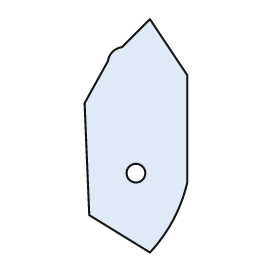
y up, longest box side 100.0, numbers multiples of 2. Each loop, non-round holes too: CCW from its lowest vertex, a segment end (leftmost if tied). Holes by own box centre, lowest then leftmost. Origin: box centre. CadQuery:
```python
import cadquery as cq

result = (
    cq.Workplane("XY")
    .moveTo(6.0, -50.0)
    .threePointArc((16.0, -36.0), (22.0, -20.0))
    .lineTo(22.0, 26.0)
    .lineTo(6.0, 50.0)
    .lineTo(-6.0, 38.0)
    .threePointArc((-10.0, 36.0), (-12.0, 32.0))
    .lineTo(-22.0, 14.0)
    .lineTo(-20.0, -34.0)
    .close()
    .moveTo(0.0, -16.0)
    .circle(4.0)
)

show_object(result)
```